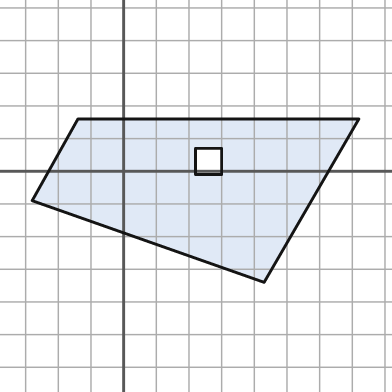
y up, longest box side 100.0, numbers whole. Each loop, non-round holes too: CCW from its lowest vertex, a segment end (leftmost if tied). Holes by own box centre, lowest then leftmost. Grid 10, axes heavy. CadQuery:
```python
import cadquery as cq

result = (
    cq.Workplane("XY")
    .moveTo(43.0, -34.0)
    .lineTo(72.0, 16.0)
    .lineTo(-14.0, 16.0)
    .lineTo(-28.0, -9.0)
    .close()
    .moveTo(22.0, -1.0)
    .lineTo(30.0, -1.0)
    .lineTo(30.0, 7.0)
    .lineTo(22.0, 7.0)
    .close()
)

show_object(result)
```